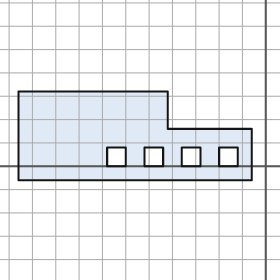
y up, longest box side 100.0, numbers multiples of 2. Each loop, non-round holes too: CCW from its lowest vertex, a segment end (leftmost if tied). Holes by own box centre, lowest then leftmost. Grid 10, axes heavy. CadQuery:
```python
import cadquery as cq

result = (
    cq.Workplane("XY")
    .moveTo(-106.0, -6.0)
    .lineTo(-6.0, -6.0)
    .lineTo(-6.0, 16.0)
    .lineTo(-42.0, 16.0)
    .lineTo(-42.0, 32.0)
    .lineTo(-106.0, 32.0)
    .close()
    .moveTo(-68.0, 0.0)
    .lineTo(-60.0, 0.0)
    .lineTo(-60.0, 8.0)
    .lineTo(-68.0, 8.0)
    .close()
    .moveTo(-52.0, 0.0)
    .lineTo(-44.0, 0.0)
    .lineTo(-44.0, 8.0)
    .lineTo(-52.0, 8.0)
    .close()
    .moveTo(-36.0, 0.0)
    .lineTo(-28.0, 0.0)
    .lineTo(-28.0, 8.0)
    .lineTo(-36.0, 8.0)
    .close()
    .moveTo(-20.0, 0.0)
    .lineTo(-12.0, 0.0)
    .lineTo(-12.0, 8.0)
    .lineTo(-20.0, 8.0)
    .close()
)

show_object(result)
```